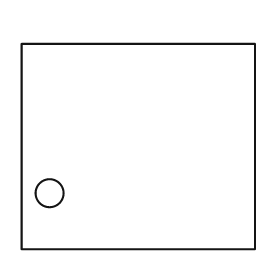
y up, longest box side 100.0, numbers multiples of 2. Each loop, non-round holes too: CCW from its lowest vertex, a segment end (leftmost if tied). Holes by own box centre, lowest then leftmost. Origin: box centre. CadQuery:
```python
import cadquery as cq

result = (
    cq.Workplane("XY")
    .moveTo(-50.0, -44.0)
    .lineTo(50.0, -44.0)
    .lineTo(50.0, 44.0)
    .lineTo(-50.0, 44.0)
    .close()
    .moveTo(-38.0, -20.0)
    .circle(6.0)
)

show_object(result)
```